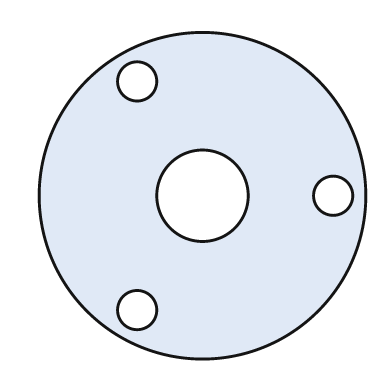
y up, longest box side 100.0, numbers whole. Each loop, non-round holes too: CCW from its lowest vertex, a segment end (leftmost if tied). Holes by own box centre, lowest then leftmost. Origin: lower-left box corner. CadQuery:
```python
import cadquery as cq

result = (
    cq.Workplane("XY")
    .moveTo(50.0, 50.0)
    .circle(50.0)
    .moveTo(30.0, 15.0)
    .circle(6.0)
    .moveTo(50.0, 50.0)
    .circle(14.0)
    .moveTo(90.0, 50.0)
    .circle(6.0)
    .moveTo(30.0, 85.0)
    .circle(6.0)
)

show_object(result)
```